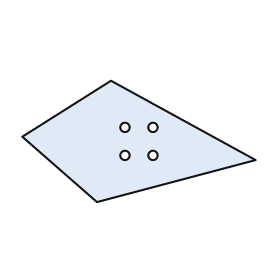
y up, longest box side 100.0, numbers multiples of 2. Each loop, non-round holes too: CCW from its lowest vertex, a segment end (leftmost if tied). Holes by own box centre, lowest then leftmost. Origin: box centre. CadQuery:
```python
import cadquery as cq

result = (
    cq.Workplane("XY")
    .moveTo(-18.0, -26.0)
    .lineTo(50.0, -8.0)
    .lineTo(-12.0, 26.0)
    .lineTo(-50.0, 2.0)
    .close()
    .moveTo(-6.0, -6.0)
    .circle(2.0)
    .moveTo(6.0, -6.0)
    .circle(2.0)
    .moveTo(-6.0, 6.0)
    .circle(2.0)
    .moveTo(6.0, 6.0)
    .circle(2.0)
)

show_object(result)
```